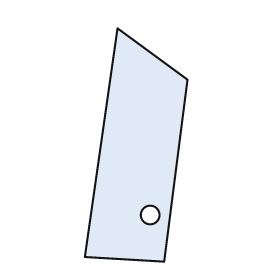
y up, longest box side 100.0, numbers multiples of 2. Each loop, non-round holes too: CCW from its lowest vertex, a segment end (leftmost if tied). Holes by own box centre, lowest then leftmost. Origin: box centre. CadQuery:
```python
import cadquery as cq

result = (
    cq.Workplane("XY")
    .moveTo(12.0, -50.0)
    .lineTo(22.0, 28.0)
    .lineTo(-8.0, 50.0)
    .lineTo(-22.0, -48.0)
    .close()
    .moveTo(6.0, -30.0)
    .circle(4.0)
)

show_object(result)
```